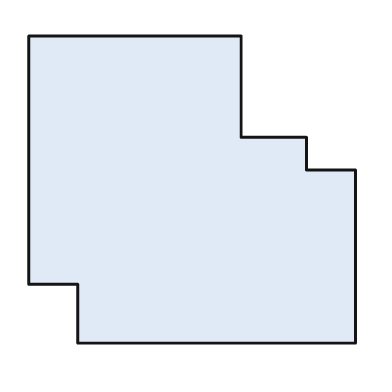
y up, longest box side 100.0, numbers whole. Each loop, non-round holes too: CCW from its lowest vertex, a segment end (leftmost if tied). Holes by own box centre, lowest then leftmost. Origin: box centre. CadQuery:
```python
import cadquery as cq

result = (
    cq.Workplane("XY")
    .moveTo(-35.0, -47.0)
    .lineTo(50.0, -47.0)
    .lineTo(50.0, 6.0)
    .lineTo(35.0, 6.0)
    .lineTo(35.0, 16.0)
    .lineTo(15.0, 16.0)
    .lineTo(15.0, 47.0)
    .lineTo(-50.0, 47.0)
    .lineTo(-50.0, -29.0)
    .lineTo(-35.0, -29.0)
    .close()
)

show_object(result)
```